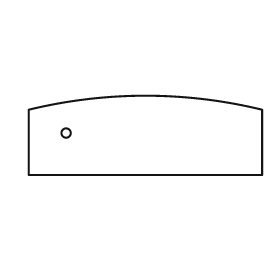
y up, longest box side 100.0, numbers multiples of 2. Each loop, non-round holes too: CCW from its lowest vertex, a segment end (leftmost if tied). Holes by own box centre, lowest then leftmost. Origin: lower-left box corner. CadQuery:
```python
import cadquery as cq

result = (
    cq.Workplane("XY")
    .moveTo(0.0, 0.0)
    .lineTo(100.0, 0.0)
    .lineTo(100.0, 28.0)
    .threePointArc((50.0, 34.0), (0.0, 28.0))
    .close()
    .moveTo(16.0, 18.0)
    .circle(2.0)
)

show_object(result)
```